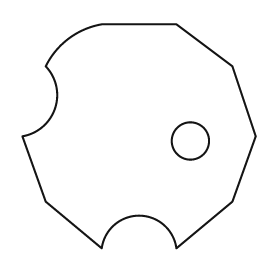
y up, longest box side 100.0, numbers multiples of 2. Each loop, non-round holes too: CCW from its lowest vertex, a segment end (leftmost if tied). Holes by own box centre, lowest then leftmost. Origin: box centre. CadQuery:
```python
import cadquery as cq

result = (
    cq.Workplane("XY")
    .moveTo(-16.0, -48.0)
    .threePointArc((0.0, -34.0), (16.0, -48.0))
    .lineTo(40.0, -28.0)
    .lineTo(50.0, 0.0)
    .lineTo(40.0, 30.0)
    .lineTo(16.0, 48.0)
    .lineTo(-16.0, 48.0)
    .threePointArc((-30.0, 42.0), (-40.0, 30.0))
    .threePointArc((-36.0, 12.0), (-50.0, 0.0))
    .lineTo(-40.0, -28.0)
    .close()
    .moveTo(22.0, -2.0)
    .circle(8.0)
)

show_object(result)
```